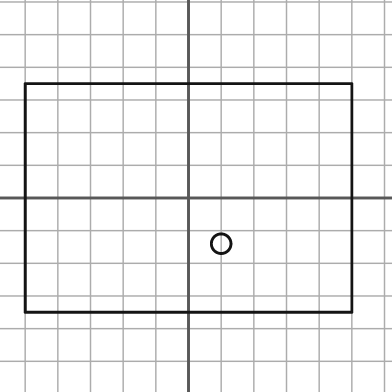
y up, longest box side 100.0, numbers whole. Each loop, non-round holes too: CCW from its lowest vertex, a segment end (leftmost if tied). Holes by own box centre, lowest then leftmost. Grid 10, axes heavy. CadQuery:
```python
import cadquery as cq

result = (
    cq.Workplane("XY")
    .moveTo(-50.0, -35.0)
    .lineTo(50.0, -35.0)
    .lineTo(50.0, 35.0)
    .lineTo(-50.0, 35.0)
    .close()
    .moveTo(10.0, -14.0)
    .circle(3.0)
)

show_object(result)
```